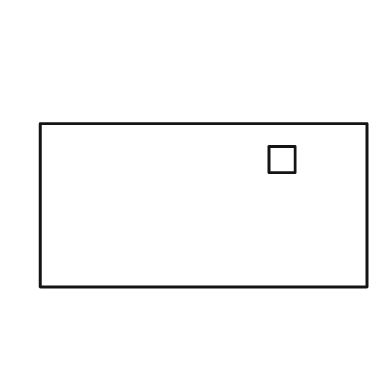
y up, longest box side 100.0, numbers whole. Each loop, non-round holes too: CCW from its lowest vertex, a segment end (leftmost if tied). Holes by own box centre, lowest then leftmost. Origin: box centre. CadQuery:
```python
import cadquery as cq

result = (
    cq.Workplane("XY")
    .moveTo(-50.0, -25.0)
    .lineTo(50.0, -25.0)
    .lineTo(50.0, 25.0)
    .lineTo(-50.0, 25.0)
    .close()
    .moveTo(20.0, 10.0)
    .lineTo(28.0, 10.0)
    .lineTo(28.0, 18.0)
    .lineTo(20.0, 18.0)
    .close()
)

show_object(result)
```